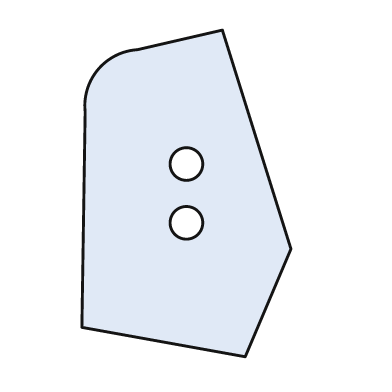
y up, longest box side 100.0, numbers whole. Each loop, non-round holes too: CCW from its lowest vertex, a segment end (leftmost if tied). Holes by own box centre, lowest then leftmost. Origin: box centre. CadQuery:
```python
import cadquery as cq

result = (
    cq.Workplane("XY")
    .moveTo(18.0, -50.0)
    .lineTo(32.0, -17.0)
    .lineTo(11.0, 50.0)
    .lineTo(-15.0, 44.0)
    .threePointArc((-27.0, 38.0), (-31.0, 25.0))
    .lineTo(-32.0, -41.0)
    .close()
    .moveTo(0.0, -9.0)
    .circle(5.0)
    .moveTo(0.0, 9.0)
    .circle(5.0)
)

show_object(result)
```